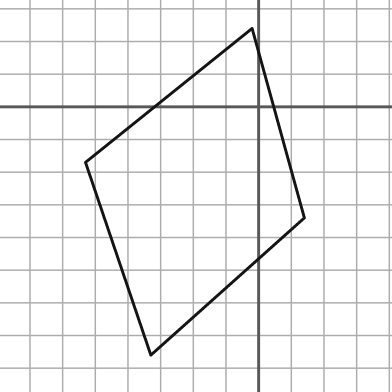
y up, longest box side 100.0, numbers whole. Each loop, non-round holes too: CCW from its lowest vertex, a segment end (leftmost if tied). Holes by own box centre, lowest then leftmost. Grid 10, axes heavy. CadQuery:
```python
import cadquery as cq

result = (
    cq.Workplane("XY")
    .moveTo(-33.0, -76.0)
    .lineTo(14.0, -34.0)
    .lineTo(-2.0, 24.0)
    .lineTo(-53.0, -17.0)
    .close()
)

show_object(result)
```